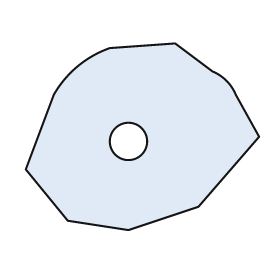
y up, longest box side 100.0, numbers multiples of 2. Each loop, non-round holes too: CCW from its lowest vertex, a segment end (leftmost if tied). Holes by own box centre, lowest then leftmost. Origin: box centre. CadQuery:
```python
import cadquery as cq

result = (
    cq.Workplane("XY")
    .moveTo(-6.0, -40.0)
    .lineTo(24.0, -30.0)
    .lineTo(50.0, 0.0)
    .lineTo(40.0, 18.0)
    .threePointArc((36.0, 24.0), (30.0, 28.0))
    .lineTo(14.0, 40.0)
    .lineTo(-14.0, 38.0)
    .threePointArc((-28.0, 30.0), (-38.0, 18.0))
    .lineTo(-50.0, -14.0)
    .lineTo(-32.0, -36.0)
    .close()
    .moveTo(-6.0, -2.0)
    .circle(8.0)
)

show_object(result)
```